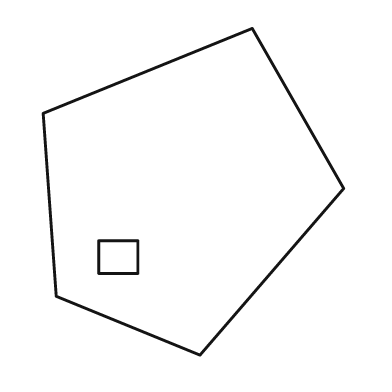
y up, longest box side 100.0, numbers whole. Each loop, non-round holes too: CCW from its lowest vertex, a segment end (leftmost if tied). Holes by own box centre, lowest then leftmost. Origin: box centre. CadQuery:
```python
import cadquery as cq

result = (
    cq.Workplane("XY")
    .moveTo(2.0, -50.0)
    .lineTo(46.0, 1.0)
    .lineTo(18.0, 50.0)
    .lineTo(-46.0, 24.0)
    .lineTo(-42.0, -32.0)
    .close()
    .moveTo(-29.0, -25.0)
    .lineTo(-17.0, -25.0)
    .lineTo(-17.0, -15.0)
    .lineTo(-29.0, -15.0)
    .close()
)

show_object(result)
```